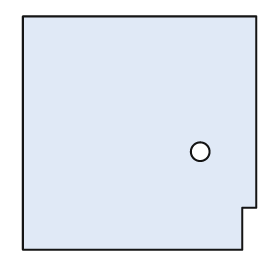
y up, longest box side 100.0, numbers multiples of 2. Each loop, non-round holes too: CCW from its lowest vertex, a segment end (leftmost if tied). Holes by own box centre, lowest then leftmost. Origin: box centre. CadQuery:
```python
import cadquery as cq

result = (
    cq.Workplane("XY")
    .moveTo(-50.0, -50.0)
    .lineTo(44.0, -50.0)
    .lineTo(44.0, -32.0)
    .lineTo(50.0, -32.0)
    .lineTo(50.0, 50.0)
    .lineTo(-50.0, 50.0)
    .close()
    .moveTo(26.0, -8.0)
    .circle(4.0)
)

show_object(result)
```